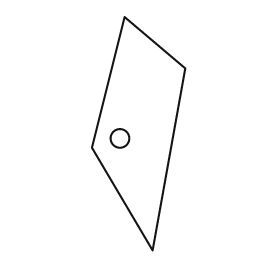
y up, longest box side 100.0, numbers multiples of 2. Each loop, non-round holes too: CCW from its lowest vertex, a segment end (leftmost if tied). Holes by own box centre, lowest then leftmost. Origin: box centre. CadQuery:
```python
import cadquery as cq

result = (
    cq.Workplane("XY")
    .moveTo(6.0, -50.0)
    .lineTo(20.0, 28.0)
    .lineTo(-6.0, 50.0)
    .lineTo(-20.0, -6.0)
    .close()
    .moveTo(-8.0, -2.0)
    .circle(4.0)
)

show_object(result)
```